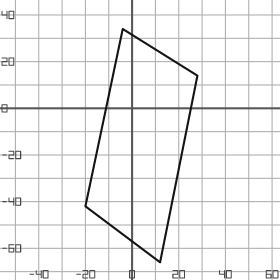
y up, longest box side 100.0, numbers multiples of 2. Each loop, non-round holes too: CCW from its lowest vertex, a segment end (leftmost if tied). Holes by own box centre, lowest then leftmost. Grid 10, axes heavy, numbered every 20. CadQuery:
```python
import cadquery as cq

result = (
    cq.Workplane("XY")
    .moveTo(12.0, -66.0)
    .lineTo(28.0, 14.0)
    .lineTo(-4.0, 34.0)
    .lineTo(-20.0, -42.0)
    .close()
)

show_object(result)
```